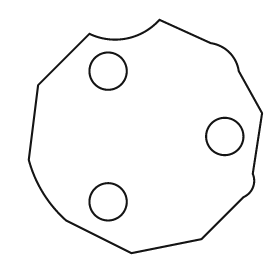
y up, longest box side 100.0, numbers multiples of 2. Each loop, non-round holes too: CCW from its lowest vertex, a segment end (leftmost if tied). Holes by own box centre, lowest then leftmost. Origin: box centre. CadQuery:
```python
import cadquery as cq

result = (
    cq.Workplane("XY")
    .moveTo(-6.0, -50.0)
    .lineTo(24.0, -44.0)
    .lineTo(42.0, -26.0)
    .threePointArc((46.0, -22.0), (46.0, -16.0))
    .lineTo(50.0, 10.0)
    .lineTo(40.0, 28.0)
    .threePointArc((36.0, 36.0), (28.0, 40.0))
    .lineTo(6.0, 50.0)
    .threePointArc((-8.0, 42.0), (-24.0, 44.0))
    .lineTo(-46.0, 22.0)
    .lineTo(-50.0, -10.0)
    .threePointArc((-44.0, -24.0), (-34.0, -36.0))
    .close()
    .moveTo(-16.0, -28.0)
    .circle(8.0)
    .moveTo(34.0, 0.0)
    .circle(8.0)
    .moveTo(-16.0, 28.0)
    .circle(8.0)
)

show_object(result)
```